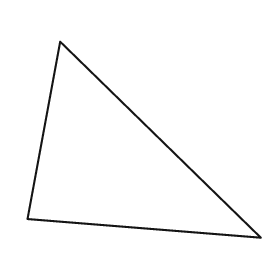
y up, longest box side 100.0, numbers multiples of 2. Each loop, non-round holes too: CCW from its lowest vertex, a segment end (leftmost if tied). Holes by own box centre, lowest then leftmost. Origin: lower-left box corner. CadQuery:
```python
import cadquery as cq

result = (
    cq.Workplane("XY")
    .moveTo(100.0, 0.0)
    .lineTo(14.0, 84.0)
    .lineTo(0.0, 8.0)
    .close()
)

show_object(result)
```